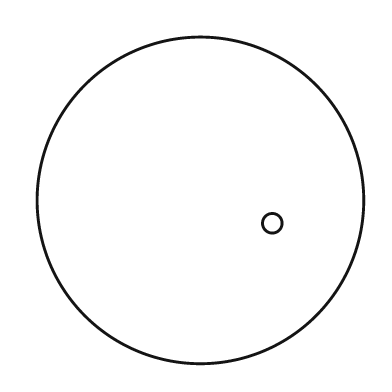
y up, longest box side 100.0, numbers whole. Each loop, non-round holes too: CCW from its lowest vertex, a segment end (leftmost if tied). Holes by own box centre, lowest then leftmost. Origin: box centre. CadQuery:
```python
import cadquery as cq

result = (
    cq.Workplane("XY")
    .moveTo(0.0, 0.0)
    .circle(50.0)
    .moveTo(22.0, -7.0)
    .circle(3.0)
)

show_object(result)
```